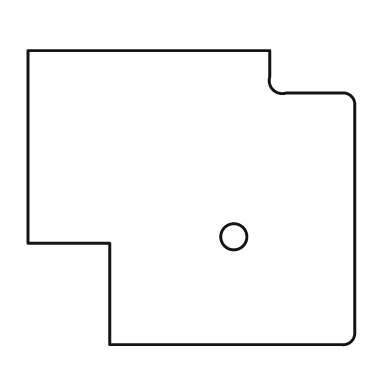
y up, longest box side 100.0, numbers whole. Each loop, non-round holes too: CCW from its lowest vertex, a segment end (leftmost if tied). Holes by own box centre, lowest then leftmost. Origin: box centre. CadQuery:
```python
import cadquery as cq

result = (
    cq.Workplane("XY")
    .moveTo(-25.0, -45.0)
    .lineTo(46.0, -45.0)
    .threePointArc((49.0, -44.0), (50.0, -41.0))
    .lineTo(50.0, 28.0)
    .threePointArc((49.0, 31.0), (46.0, 32.0))
    .lineTo(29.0, 32.0)
    .threePointArc((25.0, 33.0), (24.0, 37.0))
    .lineTo(24.0, 45.0)
    .lineTo(-50.0, 45.0)
    .lineTo(-50.0, -14.0)
    .lineTo(-25.0, -14.0)
    .close()
    .moveTo(13.0, -12.0)
    .circle(4.0)
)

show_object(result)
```